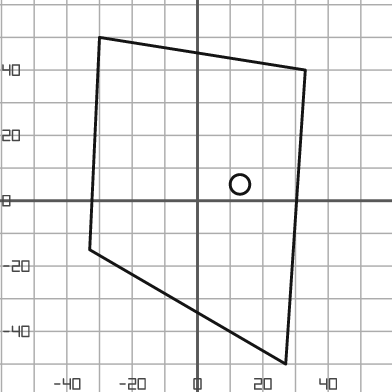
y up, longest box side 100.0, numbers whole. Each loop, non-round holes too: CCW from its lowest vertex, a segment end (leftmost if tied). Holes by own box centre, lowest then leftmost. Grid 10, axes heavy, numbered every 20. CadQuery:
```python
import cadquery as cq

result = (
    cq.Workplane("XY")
    .moveTo(27.0, -50.0)
    .lineTo(33.0, 40.0)
    .lineTo(-30.0, 50.0)
    .lineTo(-33.0, -15.0)
    .close()
    .moveTo(13.0, 5.0)
    .circle(3.0)
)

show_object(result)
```